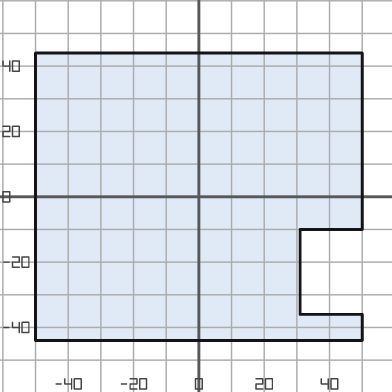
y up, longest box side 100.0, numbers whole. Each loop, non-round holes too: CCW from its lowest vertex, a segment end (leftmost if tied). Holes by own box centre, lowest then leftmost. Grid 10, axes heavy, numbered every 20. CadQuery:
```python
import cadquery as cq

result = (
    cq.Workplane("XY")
    .moveTo(-50.0, -44.0)
    .lineTo(50.0, -44.0)
    .lineTo(50.0, -36.0)
    .lineTo(31.0, -36.0)
    .lineTo(31.0, -10.0)
    .lineTo(50.0, -10.0)
    .lineTo(50.0, 44.0)
    .lineTo(-50.0, 44.0)
    .close()
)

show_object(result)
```